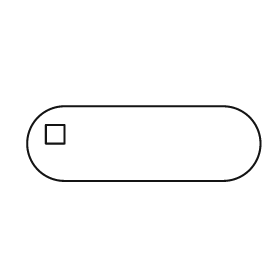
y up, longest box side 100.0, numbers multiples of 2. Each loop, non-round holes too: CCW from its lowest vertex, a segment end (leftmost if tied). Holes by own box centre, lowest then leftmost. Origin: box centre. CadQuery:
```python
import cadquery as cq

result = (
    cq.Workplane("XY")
    .moveTo(-34.0, -16.0)
    .lineTo(34.0, -16.0)
    .threePointArc((50.0, 0.0), (34.0, 16.0))
    .lineTo(-34.0, 16.0)
    .threePointArc((-50.0, 0.0), (-34.0, -16.0))
    .close()
    .moveTo(-42.0, 0.0)
    .lineTo(-34.0, 0.0)
    .lineTo(-34.0, 8.0)
    .lineTo(-42.0, 8.0)
    .close()
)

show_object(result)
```